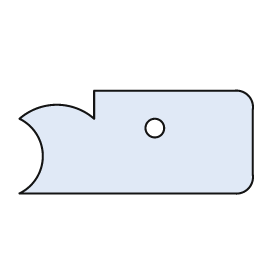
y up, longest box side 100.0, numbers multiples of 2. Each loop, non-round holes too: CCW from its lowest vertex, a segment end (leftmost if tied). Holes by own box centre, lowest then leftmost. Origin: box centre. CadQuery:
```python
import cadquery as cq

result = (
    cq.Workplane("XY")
    .moveTo(-50.0, -22.0)
    .lineTo(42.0, -22.0)
    .threePointArc((48.0, -20.0), (50.0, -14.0))
    .lineTo(50.0, 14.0)
    .threePointArc((48.0, 20.0), (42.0, 22.0))
    .lineTo(-18.0, 22.0)
    .lineTo(-18.0, 10.0)
    .threePointArc((-34.0, 16.0), (-50.0, 10.0))
    .threePointArc((-40.0, -6.0), (-50.0, -22.0))
    .close()
    .moveTo(8.0, 6.0)
    .circle(4.0)
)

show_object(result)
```